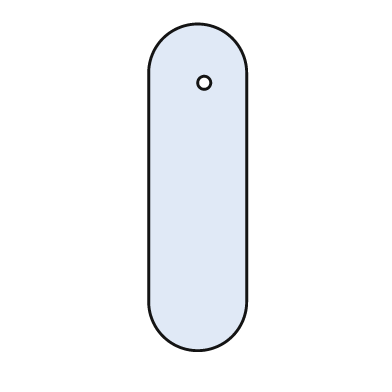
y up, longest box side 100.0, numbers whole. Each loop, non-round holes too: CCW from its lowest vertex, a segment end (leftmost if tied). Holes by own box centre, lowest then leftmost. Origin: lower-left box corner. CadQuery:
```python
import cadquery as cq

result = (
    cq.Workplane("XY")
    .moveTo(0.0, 15.0)
    .threePointArc((15.0, 0.0), (30.0, 15.0))
    .lineTo(30.0, 85.0)
    .threePointArc((15.0, 100.0), (0.0, 85.0))
    .close()
    .moveTo(17.0, 82.0)
    .circle(2.0)
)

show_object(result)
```